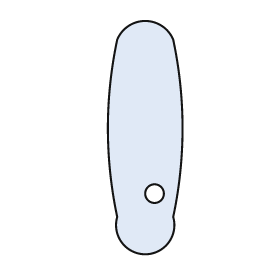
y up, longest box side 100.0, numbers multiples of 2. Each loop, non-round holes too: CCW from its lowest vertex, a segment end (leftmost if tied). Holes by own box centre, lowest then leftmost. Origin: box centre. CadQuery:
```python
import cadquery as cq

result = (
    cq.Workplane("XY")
    .moveTo(-12.0, -34.0)
    .threePointArc((0.0, -50.0), (12.0, -34.0))
    .threePointArc((16.0, 4.0), (12.0, 42.0))
    .threePointArc((0.0, 50.0), (-12.0, 42.0))
    .threePointArc((-16.0, 4.0), (-12.0, -34.0))
    .close()
    .moveTo(4.0, -24.0)
    .circle(4.0)
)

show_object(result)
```